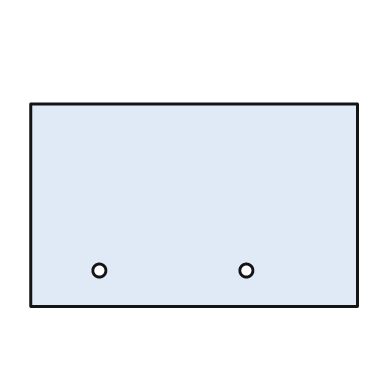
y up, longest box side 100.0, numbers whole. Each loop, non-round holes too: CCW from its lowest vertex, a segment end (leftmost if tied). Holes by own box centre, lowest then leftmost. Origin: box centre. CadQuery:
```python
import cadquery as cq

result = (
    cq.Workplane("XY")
    .moveTo(-50.0, -31.0)
    .lineTo(50.0, -31.0)
    .lineTo(50.0, 31.0)
    .lineTo(-50.0, 31.0)
    .close()
    .moveTo(-29.0, -20.0)
    .circle(2.0)
    .moveTo(16.0, -20.0)
    .circle(2.0)
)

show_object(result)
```